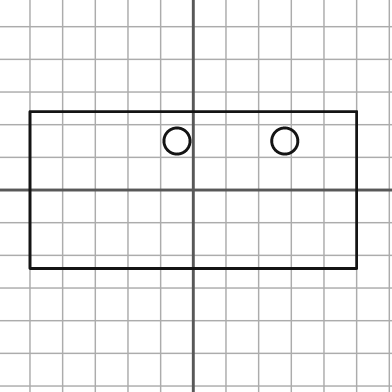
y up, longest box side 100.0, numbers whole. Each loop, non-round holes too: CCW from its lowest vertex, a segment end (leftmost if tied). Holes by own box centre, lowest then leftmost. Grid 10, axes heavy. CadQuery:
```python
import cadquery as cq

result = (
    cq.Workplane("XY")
    .moveTo(-50.0, -24.0)
    .lineTo(50.0, -24.0)
    .lineTo(50.0, 24.0)
    .lineTo(-50.0, 24.0)
    .close()
    .moveTo(-5.0, 15.0)
    .circle(4.0)
    .moveTo(28.0, 15.0)
    .circle(4.0)
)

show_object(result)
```